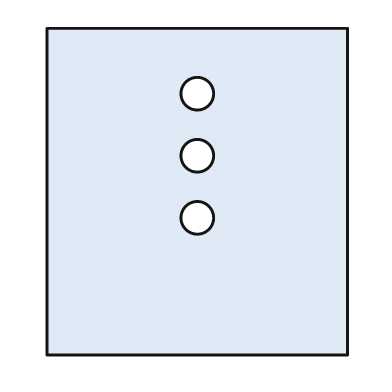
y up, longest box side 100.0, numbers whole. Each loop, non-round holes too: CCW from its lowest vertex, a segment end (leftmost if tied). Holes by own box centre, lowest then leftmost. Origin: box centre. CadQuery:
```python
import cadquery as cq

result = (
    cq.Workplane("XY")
    .moveTo(-46.0, -50.0)
    .lineTo(46.0, -50.0)
    .lineTo(46.0, 50.0)
    .lineTo(-46.0, 50.0)
    .close()
    .moveTo(0.0, -8.0)
    .circle(5.0)
    .moveTo(0.0, 11.0)
    .circle(5.0)
    .moveTo(0.0, 30.0)
    .circle(5.0)
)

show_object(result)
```